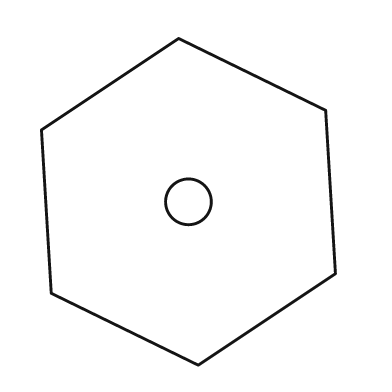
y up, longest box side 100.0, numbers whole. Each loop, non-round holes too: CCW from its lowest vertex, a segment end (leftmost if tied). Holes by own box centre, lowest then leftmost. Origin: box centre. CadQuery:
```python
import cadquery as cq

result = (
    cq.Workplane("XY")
    .moveTo(3.0, -50.0)
    .lineTo(45.0, -22.0)
    .lineTo(42.0, 28.0)
    .lineTo(-3.0, 50.0)
    .lineTo(-45.0, 22.0)
    .lineTo(-42.0, -28.0)
    .close()
    .moveTo(0.0, 0.0)
    .circle(7.0)
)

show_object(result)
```